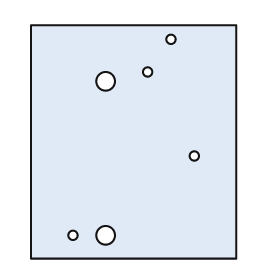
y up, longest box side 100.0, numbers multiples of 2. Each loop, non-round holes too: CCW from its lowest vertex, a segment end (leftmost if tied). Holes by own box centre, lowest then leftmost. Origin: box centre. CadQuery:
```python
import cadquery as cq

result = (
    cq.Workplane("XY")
    .moveTo(-44.0, -50.0)
    .lineTo(44.0, -50.0)
    .lineTo(44.0, 50.0)
    .lineTo(-44.0, 50.0)
    .close()
    .moveTo(-26.0, -40.0)
    .circle(2.0)
    .moveTo(-12.0, -40.0)
    .circle(4.0)
    .moveTo(26.0, -6.0)
    .circle(2.0)
    .moveTo(-12.0, 26.0)
    .circle(4.0)
    .moveTo(6.0, 30.0)
    .circle(2.0)
    .moveTo(16.0, 44.0)
    .circle(2.0)
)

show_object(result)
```